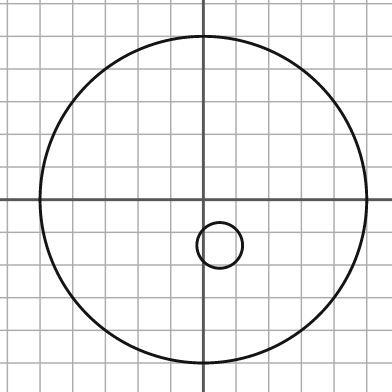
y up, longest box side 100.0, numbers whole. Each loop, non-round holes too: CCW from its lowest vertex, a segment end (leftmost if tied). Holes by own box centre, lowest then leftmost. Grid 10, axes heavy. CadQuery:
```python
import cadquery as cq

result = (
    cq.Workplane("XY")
    .moveTo(0.0, 0.0)
    .circle(50.0)
    .moveTo(5.0, -14.0)
    .circle(7.0)
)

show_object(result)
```